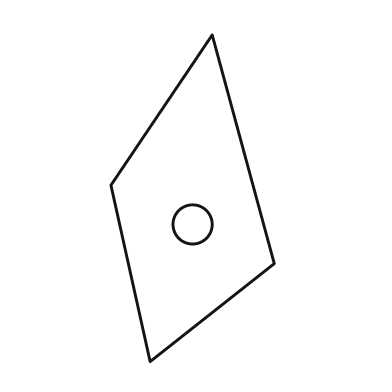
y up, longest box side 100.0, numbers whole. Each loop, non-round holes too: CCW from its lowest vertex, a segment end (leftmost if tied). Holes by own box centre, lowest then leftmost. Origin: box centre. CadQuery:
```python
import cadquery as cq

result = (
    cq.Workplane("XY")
    .moveTo(-13.0, -50.0)
    .lineTo(25.0, -20.0)
    .lineTo(6.0, 50.0)
    .lineTo(-25.0, 4.0)
    .close()
    .moveTo(0.0, -8.0)
    .circle(6.0)
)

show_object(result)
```